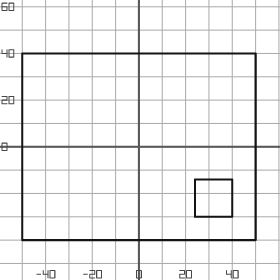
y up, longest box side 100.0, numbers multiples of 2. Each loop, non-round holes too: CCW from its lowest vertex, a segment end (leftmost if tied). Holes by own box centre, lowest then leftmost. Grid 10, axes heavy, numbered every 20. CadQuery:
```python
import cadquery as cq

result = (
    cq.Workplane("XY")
    .moveTo(-50.0, -40.0)
    .lineTo(50.0, -40.0)
    .lineTo(50.0, 40.0)
    .lineTo(-50.0, 40.0)
    .close()
    .moveTo(24.0, -30.0)
    .lineTo(40.0, -30.0)
    .lineTo(40.0, -14.0)
    .lineTo(24.0, -14.0)
    .close()
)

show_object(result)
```